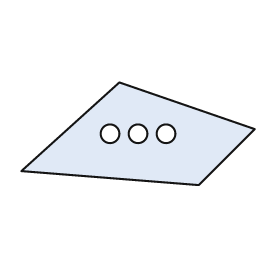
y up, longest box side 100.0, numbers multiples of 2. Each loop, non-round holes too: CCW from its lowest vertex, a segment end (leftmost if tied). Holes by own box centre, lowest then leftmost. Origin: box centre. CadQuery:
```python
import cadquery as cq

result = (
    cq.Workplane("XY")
    .moveTo(26.0, -22.0)
    .lineTo(50.0, 2.0)
    .lineTo(-8.0, 22.0)
    .lineTo(-50.0, -16.0)
    .close()
    .moveTo(-12.0, 0.0)
    .circle(4.0)
    .moveTo(0.0, 0.0)
    .circle(4.0)
    .moveTo(12.0, 0.0)
    .circle(4.0)
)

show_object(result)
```